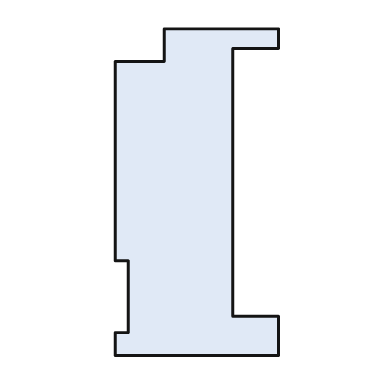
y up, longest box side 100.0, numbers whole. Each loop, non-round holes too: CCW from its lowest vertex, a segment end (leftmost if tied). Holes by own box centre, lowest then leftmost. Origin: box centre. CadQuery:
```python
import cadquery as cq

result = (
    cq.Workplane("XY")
    .moveTo(-25.0, -50.0)
    .lineTo(25.0, -50.0)
    .lineTo(25.0, -38.0)
    .lineTo(11.0, -38.0)
    .lineTo(11.0, 44.0)
    .lineTo(25.0, 44.0)
    .lineTo(25.0, 50.0)
    .lineTo(-10.0, 50.0)
    .lineTo(-10.0, 40.0)
    .lineTo(-25.0, 40.0)
    .lineTo(-25.0, -21.0)
    .lineTo(-21.0, -21.0)
    .lineTo(-21.0, -43.0)
    .lineTo(-25.0, -43.0)
    .close()
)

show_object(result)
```